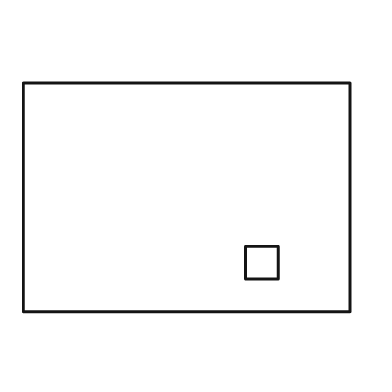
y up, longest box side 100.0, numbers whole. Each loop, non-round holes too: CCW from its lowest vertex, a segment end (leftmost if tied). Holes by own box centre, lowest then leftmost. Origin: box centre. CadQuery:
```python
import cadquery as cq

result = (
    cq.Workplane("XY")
    .moveTo(-50.0, -35.0)
    .lineTo(50.0, -35.0)
    .lineTo(50.0, 35.0)
    .lineTo(-50.0, 35.0)
    .close()
    .moveTo(18.0, -25.0)
    .lineTo(28.0, -25.0)
    .lineTo(28.0, -15.0)
    .lineTo(18.0, -15.0)
    .close()
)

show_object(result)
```